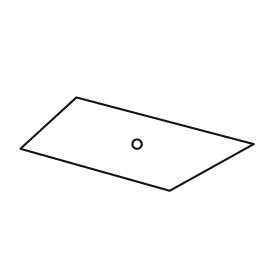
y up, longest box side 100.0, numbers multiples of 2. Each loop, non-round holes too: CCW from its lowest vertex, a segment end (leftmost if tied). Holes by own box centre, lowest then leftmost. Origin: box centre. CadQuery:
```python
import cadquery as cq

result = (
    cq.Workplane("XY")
    .moveTo(14.0, -20.0)
    .lineTo(50.0, 0.0)
    .lineTo(-26.0, 20.0)
    .lineTo(-50.0, -2.0)
    .close()
    .moveTo(0.0, 0.0)
    .circle(2.0)
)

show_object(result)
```